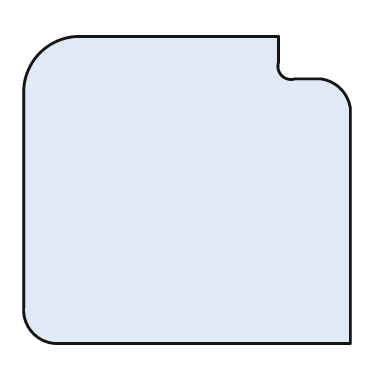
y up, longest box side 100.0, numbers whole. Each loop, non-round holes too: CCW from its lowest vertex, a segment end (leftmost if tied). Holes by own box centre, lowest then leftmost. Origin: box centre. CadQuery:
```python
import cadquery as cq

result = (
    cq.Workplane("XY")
    .moveTo(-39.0, -47.0)
    .lineTo(50.0, -47.0)
    .lineTo(50.0, 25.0)
    .threePointArc((47.0, 31.0), (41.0, 34.0))
    .lineTo(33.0, 34.0)
    .threePointArc((29.0, 35.0), (28.0, 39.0))
    .lineTo(28.0, 47.0)
    .lineTo(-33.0, 47.0)
    .threePointArc((-45.0, 42.0), (-50.0, 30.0))
    .lineTo(-50.0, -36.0)
    .threePointArc((-47.0, -44.0), (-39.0, -47.0))
    .close()
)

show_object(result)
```